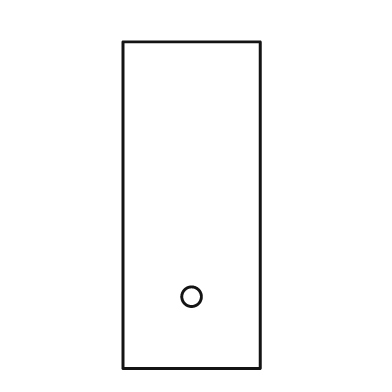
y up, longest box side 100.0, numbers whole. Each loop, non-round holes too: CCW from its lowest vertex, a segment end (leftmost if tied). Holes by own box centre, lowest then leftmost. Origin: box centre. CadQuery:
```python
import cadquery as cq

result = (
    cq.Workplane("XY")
    .moveTo(-21.0, -50.0)
    .lineTo(21.0, -50.0)
    .lineTo(21.0, 50.0)
    .lineTo(-21.0, 50.0)
    .close()
    .moveTo(0.0, -28.0)
    .circle(3.0)
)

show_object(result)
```